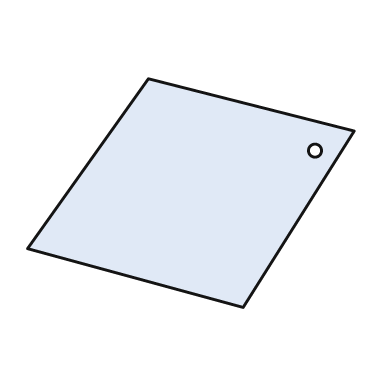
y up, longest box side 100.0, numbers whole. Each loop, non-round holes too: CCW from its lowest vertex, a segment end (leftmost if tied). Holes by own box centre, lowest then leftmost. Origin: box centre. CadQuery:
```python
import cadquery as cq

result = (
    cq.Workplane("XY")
    .moveTo(16.0, -35.0)
    .lineTo(50.0, 19.0)
    .lineTo(-13.0, 35.0)
    .lineTo(-50.0, -17.0)
    .close()
    .moveTo(38.0, 13.0)
    .circle(2.0)
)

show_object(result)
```